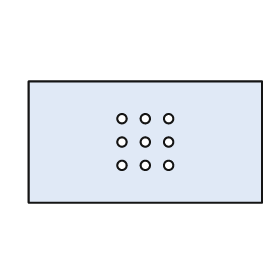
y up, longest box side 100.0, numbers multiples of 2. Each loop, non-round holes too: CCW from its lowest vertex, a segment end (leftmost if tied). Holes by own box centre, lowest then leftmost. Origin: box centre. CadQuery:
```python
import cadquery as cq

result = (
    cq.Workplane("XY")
    .moveTo(-50.0, -26.0)
    .lineTo(50.0, -26.0)
    .lineTo(50.0, 26.0)
    .lineTo(-50.0, 26.0)
    .close()
    .moveTo(-10.0, -10.0)
    .circle(2.0)
    .moveTo(0.0, -10.0)
    .circle(2.0)
    .moveTo(10.0, -10.0)
    .circle(2.0)
    .moveTo(-10.0, 0.0)
    .circle(2.0)
    .moveTo(0.0, 0.0)
    .circle(2.0)
    .moveTo(10.0, 0.0)
    .circle(2.0)
    .moveTo(-10.0, 10.0)
    .circle(2.0)
    .moveTo(0.0, 10.0)
    .circle(2.0)
    .moveTo(10.0, 10.0)
    .circle(2.0)
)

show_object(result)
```